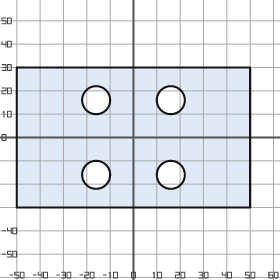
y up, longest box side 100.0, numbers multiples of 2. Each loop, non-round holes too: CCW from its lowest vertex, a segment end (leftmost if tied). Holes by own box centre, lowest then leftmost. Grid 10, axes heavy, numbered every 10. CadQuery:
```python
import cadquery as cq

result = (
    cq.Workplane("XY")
    .moveTo(-50.0, -30.0)
    .lineTo(50.0, -30.0)
    .lineTo(50.0, 30.0)
    .lineTo(-50.0, 30.0)
    .close()
    .moveTo(-16.0, -16.0)
    .circle(6.0)
    .moveTo(16.0, -16.0)
    .circle(6.0)
    .moveTo(-16.0, 16.0)
    .circle(6.0)
    .moveTo(16.0, 16.0)
    .circle(6.0)
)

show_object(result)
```